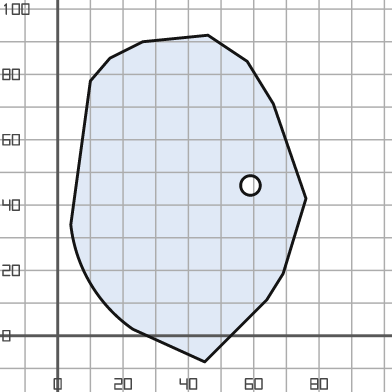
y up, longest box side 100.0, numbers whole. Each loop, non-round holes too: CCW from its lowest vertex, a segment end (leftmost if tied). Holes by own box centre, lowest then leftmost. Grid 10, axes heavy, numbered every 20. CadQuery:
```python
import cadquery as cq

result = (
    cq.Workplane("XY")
    .moveTo(45.0, -8.0)
    .lineTo(64.0, 11.0)
    .lineTo(69.0, 19.0)
    .lineTo(76.0, 42.0)
    .lineTo(66.0, 71.0)
    .lineTo(58.0, 84.0)
    .lineTo(46.0, 92.0)
    .lineTo(26.0, 90.0)
    .lineTo(16.0, 85.0)
    .lineTo(10.0, 78.0)
    .lineTo(4.0, 34.0)
    .threePointArc((10.0, 16.0), (23.0, 2.0))
    .close()
    .moveTo(59.0, 46.0)
    .circle(3.0)
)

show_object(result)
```